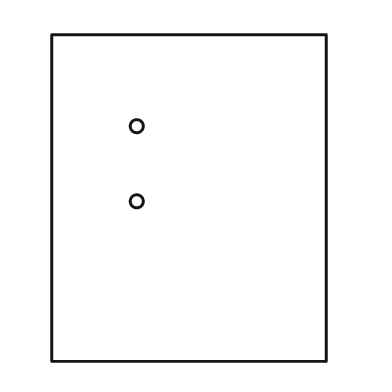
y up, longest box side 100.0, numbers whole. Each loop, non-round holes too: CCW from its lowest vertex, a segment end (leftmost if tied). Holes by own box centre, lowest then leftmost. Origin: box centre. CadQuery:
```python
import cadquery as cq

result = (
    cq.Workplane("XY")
    .moveTo(-42.0, -50.0)
    .lineTo(42.0, -50.0)
    .lineTo(42.0, 50.0)
    .lineTo(-42.0, 50.0)
    .close()
    .moveTo(-16.0, -1.0)
    .circle(2.0)
    .moveTo(-16.0, 22.0)
    .circle(2.0)
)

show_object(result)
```